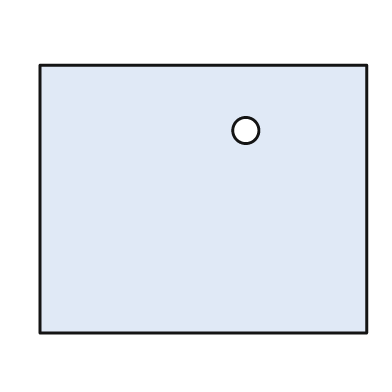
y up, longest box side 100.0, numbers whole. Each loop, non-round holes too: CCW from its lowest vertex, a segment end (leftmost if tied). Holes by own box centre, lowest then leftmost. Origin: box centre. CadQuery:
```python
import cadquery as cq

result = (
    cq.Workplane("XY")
    .moveTo(-50.0, -41.0)
    .lineTo(50.0, -41.0)
    .lineTo(50.0, 41.0)
    .lineTo(-50.0, 41.0)
    .close()
    .moveTo(13.0, 21.0)
    .circle(4.0)
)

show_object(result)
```